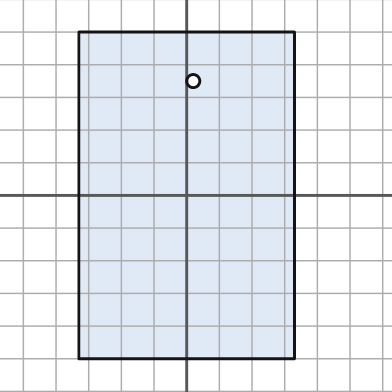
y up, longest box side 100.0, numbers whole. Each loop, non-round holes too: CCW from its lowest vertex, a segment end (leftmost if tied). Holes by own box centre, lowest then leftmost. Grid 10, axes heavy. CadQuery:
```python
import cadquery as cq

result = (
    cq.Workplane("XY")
    .moveTo(-33.0, -50.0)
    .lineTo(33.0, -50.0)
    .lineTo(33.0, 50.0)
    .lineTo(-33.0, 50.0)
    .close()
    .moveTo(2.0, 35.0)
    .circle(2.0)
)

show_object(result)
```